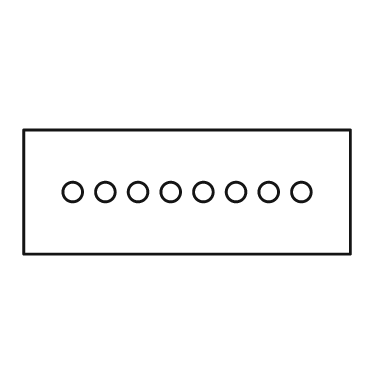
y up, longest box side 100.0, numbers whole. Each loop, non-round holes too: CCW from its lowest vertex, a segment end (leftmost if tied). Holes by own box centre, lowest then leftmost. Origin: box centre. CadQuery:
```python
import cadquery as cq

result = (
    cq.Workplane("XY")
    .moveTo(-50.0, -19.0)
    .lineTo(50.0, -19.0)
    .lineTo(50.0, 19.0)
    .lineTo(-50.0, 19.0)
    .close()
    .moveTo(-35.0, 0.0)
    .circle(3.0)
    .moveTo(-25.0, 0.0)
    .circle(3.0)
    .moveTo(-15.0, 0.0)
    .circle(3.0)
    .moveTo(-5.0, 0.0)
    .circle(3.0)
    .moveTo(5.0, 0.0)
    .circle(3.0)
    .moveTo(15.0, 0.0)
    .circle(3.0)
    .moveTo(25.0, 0.0)
    .circle(3.0)
    .moveTo(35.0, 0.0)
    .circle(3.0)
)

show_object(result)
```